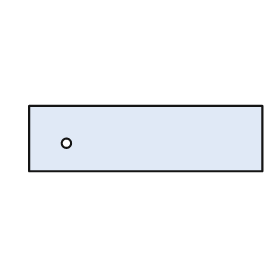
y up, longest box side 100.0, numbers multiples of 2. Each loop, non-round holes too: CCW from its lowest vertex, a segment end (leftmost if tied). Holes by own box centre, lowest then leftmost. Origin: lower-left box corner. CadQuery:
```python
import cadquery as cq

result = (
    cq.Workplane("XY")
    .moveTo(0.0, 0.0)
    .lineTo(100.0, 0.0)
    .lineTo(100.0, 28.0)
    .lineTo(0.0, 28.0)
    .close()
    .moveTo(16.0, 12.0)
    .circle(2.0)
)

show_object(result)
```